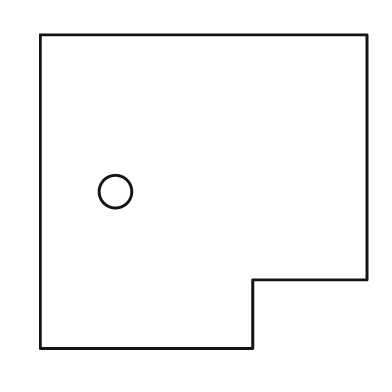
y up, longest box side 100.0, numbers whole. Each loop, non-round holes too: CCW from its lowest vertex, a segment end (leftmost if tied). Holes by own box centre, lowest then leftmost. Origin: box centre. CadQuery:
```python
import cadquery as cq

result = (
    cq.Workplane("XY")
    .moveTo(-50.0, -48.0)
    .lineTo(15.0, -48.0)
    .lineTo(15.0, -27.0)
    .lineTo(50.0, -27.0)
    .lineTo(50.0, 48.0)
    .lineTo(-50.0, 48.0)
    .close()
    .moveTo(-27.0, 0.0)
    .circle(5.0)
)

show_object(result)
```